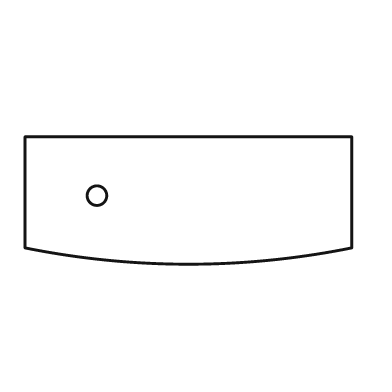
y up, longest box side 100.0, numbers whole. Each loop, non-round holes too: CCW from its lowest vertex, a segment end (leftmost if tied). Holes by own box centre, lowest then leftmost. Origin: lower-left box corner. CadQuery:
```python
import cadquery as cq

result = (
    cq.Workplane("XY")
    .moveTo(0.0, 5.0)
    .threePointArc((50.0, 0.0), (100.0, 5.0))
    .lineTo(100.0, 39.0)
    .lineTo(0.0, 39.0)
    .close()
    .moveTo(22.0, 21.0)
    .circle(3.0)
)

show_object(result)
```